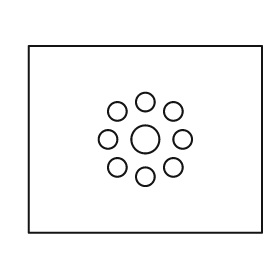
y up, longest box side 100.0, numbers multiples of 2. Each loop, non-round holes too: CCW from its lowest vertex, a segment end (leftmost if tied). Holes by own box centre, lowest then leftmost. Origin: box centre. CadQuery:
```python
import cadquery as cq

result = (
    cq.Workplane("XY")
    .moveTo(-50.0, -40.0)
    .lineTo(50.0, -40.0)
    .lineTo(50.0, 40.0)
    .lineTo(-50.0, 40.0)
    .close()
    .moveTo(0.0, -16.0)
    .circle(4.0)
    .moveTo(-12.0, -12.0)
    .circle(4.0)
    .moveTo(12.0, -12.0)
    .circle(4.0)
    .moveTo(-16.0, 0.0)
    .circle(4.0)
    .moveTo(0.0, 0.0)
    .circle(6.0)
    .moveTo(16.0, 0.0)
    .circle(4.0)
    .moveTo(-12.0, 12.0)
    .circle(4.0)
    .moveTo(12.0, 12.0)
    .circle(4.0)
    .moveTo(0.0, 16.0)
    .circle(4.0)
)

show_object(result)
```